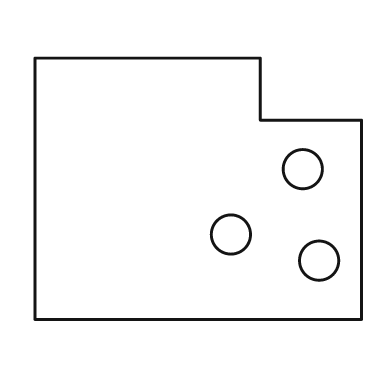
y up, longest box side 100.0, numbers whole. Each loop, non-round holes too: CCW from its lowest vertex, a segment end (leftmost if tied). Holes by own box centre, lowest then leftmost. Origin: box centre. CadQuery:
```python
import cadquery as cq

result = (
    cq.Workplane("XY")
    .moveTo(-50.0, -40.0)
    .lineTo(50.0, -40.0)
    .lineTo(50.0, 21.0)
    .lineTo(19.0, 21.0)
    .lineTo(19.0, 40.0)
    .lineTo(-50.0, 40.0)
    .close()
    .moveTo(37.0, -22.0)
    .circle(6.0)
    .moveTo(10.0, -14.0)
    .circle(6.0)
    .moveTo(32.0, 6.0)
    .circle(6.0)
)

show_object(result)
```